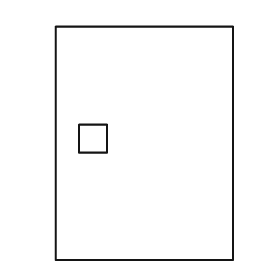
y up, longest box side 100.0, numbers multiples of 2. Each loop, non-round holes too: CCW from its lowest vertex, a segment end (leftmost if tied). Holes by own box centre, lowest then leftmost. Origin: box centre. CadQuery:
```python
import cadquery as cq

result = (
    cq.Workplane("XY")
    .moveTo(-38.0, -50.0)
    .lineTo(38.0, -50.0)
    .lineTo(38.0, 50.0)
    .lineTo(-38.0, 50.0)
    .close()
    .moveTo(-28.0, -4.0)
    .lineTo(-16.0, -4.0)
    .lineTo(-16.0, 8.0)
    .lineTo(-28.0, 8.0)
    .close()
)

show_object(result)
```